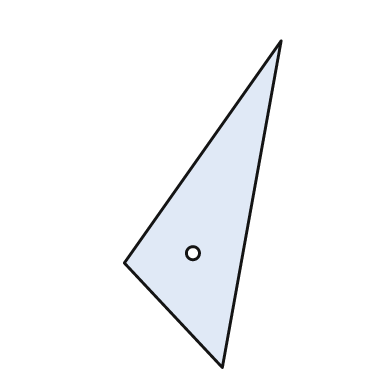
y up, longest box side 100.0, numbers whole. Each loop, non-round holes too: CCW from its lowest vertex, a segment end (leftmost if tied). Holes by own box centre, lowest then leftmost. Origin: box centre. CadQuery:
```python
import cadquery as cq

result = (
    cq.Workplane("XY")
    .moveTo(6.0, -50.0)
    .lineTo(24.0, 50.0)
    .lineTo(-24.0, -18.0)
    .close()
    .moveTo(-3.0, -15.0)
    .circle(2.0)
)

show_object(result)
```